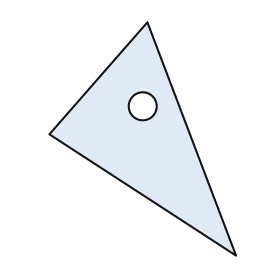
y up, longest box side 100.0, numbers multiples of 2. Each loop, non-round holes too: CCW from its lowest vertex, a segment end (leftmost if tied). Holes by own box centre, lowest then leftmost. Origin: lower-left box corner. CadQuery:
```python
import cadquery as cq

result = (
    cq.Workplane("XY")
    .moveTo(80.0, 0.0)
    .lineTo(42.0, 100.0)
    .lineTo(0.0, 52.0)
    .close()
    .moveTo(40.0, 64.0)
    .circle(6.0)
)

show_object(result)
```